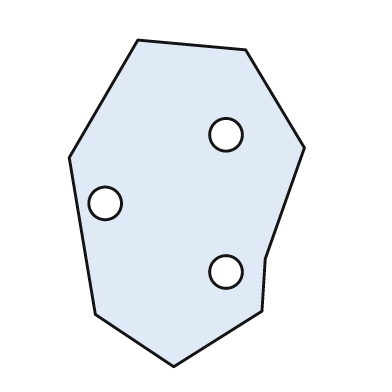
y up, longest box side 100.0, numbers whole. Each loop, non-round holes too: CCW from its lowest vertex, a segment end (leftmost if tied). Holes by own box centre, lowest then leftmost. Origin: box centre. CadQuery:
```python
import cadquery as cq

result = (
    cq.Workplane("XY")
    .moveTo(-4.0, -50.0)
    .lineTo(23.0, -33.0)
    .lineTo(24.0, -17.0)
    .lineTo(36.0, 17.0)
    .lineTo(18.0, 47.0)
    .lineTo(-15.0, 50.0)
    .lineTo(-36.0, 14.0)
    .lineTo(-28.0, -34.0)
    .close()
    .moveTo(12.0, -21.0)
    .circle(5.0)
    .moveTo(-25.0, 0.0)
    .circle(5.0)
    .moveTo(12.0, 21.0)
    .circle(5.0)
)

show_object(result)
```